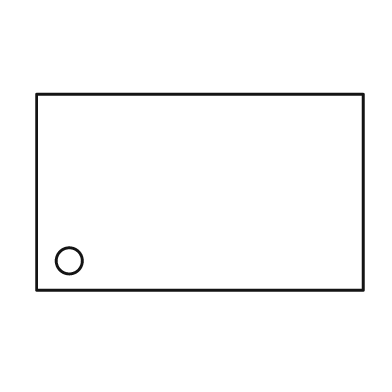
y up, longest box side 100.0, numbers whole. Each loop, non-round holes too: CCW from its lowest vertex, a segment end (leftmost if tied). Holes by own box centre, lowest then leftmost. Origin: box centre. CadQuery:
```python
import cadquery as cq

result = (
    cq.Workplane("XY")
    .moveTo(-50.0, -30.0)
    .lineTo(50.0, -30.0)
    .lineTo(50.0, 30.0)
    .lineTo(-50.0, 30.0)
    .close()
    .moveTo(-40.0, -21.0)
    .circle(4.0)
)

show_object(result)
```